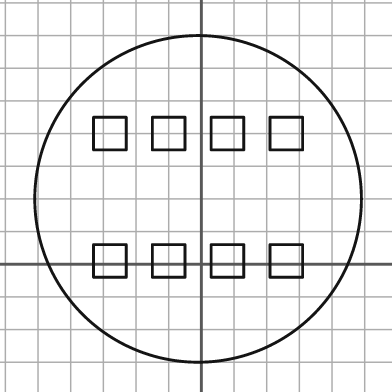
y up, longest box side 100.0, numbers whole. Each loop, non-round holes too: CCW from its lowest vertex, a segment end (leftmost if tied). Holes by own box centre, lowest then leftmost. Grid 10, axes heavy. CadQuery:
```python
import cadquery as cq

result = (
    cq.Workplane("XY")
    .moveTo(-1.0, 20.0)
    .circle(50.0)
    .moveTo(-33.0, -4.0)
    .lineTo(-23.0, -4.0)
    .lineTo(-23.0, 6.0)
    .lineTo(-33.0, 6.0)
    .close()
    .moveTo(-15.0, -4.0)
    .lineTo(-5.0, -4.0)
    .lineTo(-5.0, 6.0)
    .lineTo(-15.0, 6.0)
    .close()
    .moveTo(3.0, -4.0)
    .lineTo(13.0, -4.0)
    .lineTo(13.0, 6.0)
    .lineTo(3.0, 6.0)
    .close()
    .moveTo(21.0, -4.0)
    .lineTo(31.0, -4.0)
    .lineTo(31.0, 6.0)
    .lineTo(21.0, 6.0)
    .close()
    .moveTo(-33.0, 35.0)
    .lineTo(-23.0, 35.0)
    .lineTo(-23.0, 45.0)
    .lineTo(-33.0, 45.0)
    .close()
    .moveTo(-15.0, 35.0)
    .lineTo(-5.0, 35.0)
    .lineTo(-5.0, 45.0)
    .lineTo(-15.0, 45.0)
    .close()
    .moveTo(3.0, 35.0)
    .lineTo(13.0, 35.0)
    .lineTo(13.0, 45.0)
    .lineTo(3.0, 45.0)
    .close()
    .moveTo(21.0, 35.0)
    .lineTo(31.0, 35.0)
    .lineTo(31.0, 45.0)
    .lineTo(21.0, 45.0)
    .close()
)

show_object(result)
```